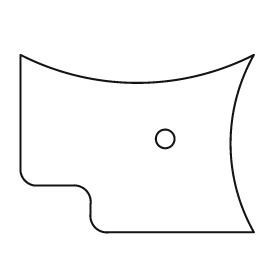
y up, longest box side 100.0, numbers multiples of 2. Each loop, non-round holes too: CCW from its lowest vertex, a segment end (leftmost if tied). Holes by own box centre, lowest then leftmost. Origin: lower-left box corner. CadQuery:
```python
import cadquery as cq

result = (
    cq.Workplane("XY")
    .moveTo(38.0, 0.0)
    .lineTo(100.0, 0.0)
    .threePointArc((90.0, 38.0), (100.0, 76.0))
    .threePointArc((50.0, 64.0), (0.0, 76.0))
    .lineTo(0.0, 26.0)
    .threePointArc((2.0, 22.0), (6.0, 20.0))
    .lineTo(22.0, 20.0)
    .threePointArc((28.0, 18.0), (30.0, 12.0))
    .lineTo(30.0, 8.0)
    .threePointArc((32.0, 2.0), (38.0, 0.0))
    .close()
    .moveTo(62.0, 40.0)
    .circle(4.0)
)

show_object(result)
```